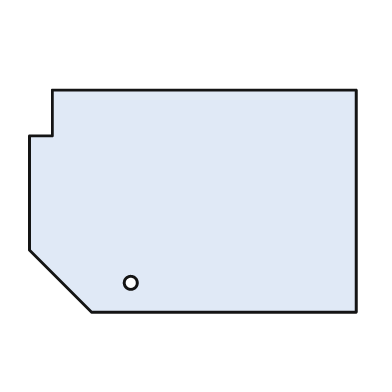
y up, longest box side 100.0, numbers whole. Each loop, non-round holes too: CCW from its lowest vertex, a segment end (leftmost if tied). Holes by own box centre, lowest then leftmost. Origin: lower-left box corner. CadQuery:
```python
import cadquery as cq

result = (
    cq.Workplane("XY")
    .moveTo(19.0, 0.0)
    .lineTo(100.0, 0.0)
    .lineTo(100.0, 68.0)
    .lineTo(7.0, 68.0)
    .lineTo(7.0, 54.0)
    .lineTo(0.0, 54.0)
    .lineTo(0.0, 19.0)
    .close()
    .moveTo(31.0, 9.0)
    .circle(2.0)
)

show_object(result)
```